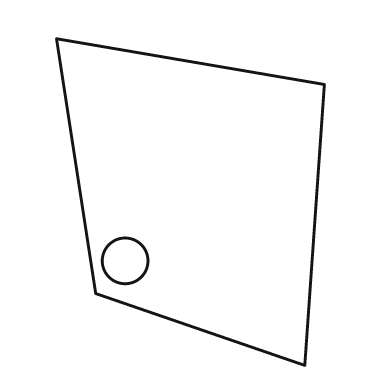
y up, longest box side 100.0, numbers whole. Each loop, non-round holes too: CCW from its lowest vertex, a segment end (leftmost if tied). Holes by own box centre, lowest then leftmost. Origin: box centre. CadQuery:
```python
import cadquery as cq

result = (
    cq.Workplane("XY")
    .moveTo(35.0, -50.0)
    .lineTo(41.0, 36.0)
    .lineTo(-41.0, 50.0)
    .lineTo(-29.0, -28.0)
    .close()
    .moveTo(-20.0, -18.0)
    .circle(7.0)
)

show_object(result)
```